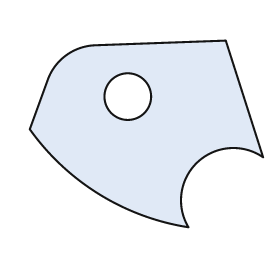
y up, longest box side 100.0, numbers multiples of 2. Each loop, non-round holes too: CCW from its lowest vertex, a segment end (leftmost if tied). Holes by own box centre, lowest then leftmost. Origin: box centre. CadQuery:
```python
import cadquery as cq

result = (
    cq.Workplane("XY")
    .moveTo(18.0, -40.0)
    .threePointArc((22.0, -12.0), (50.0, -10.0))
    .lineTo(34.0, 40.0)
    .lineTo(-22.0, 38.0)
    .threePointArc((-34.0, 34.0), (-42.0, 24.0))
    .lineTo(-50.0, 2.0)
    .threePointArc((-20.0, -26.0), (18.0, -40.0))
    .close()
    .moveTo(-8.0, 16.0)
    .circle(10.0)
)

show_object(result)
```